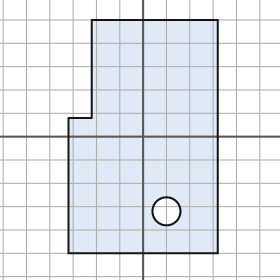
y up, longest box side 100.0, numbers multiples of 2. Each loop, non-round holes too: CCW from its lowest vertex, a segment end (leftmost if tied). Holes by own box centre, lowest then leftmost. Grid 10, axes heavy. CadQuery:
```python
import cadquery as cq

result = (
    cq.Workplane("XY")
    .moveTo(-32.0, -50.0)
    .lineTo(32.0, -50.0)
    .lineTo(32.0, 50.0)
    .lineTo(-22.0, 50.0)
    .lineTo(-22.0, 8.0)
    .lineTo(-32.0, 8.0)
    .close()
    .moveTo(10.0, -32.0)
    .circle(6.0)
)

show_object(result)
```